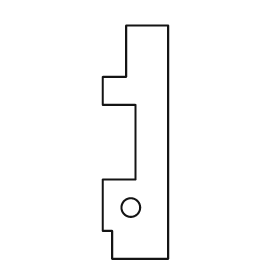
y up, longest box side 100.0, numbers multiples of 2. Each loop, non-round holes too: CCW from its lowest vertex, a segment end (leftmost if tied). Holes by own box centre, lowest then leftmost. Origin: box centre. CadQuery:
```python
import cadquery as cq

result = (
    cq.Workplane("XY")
    .moveTo(-10.0, -50.0)
    .lineTo(14.0, -50.0)
    .lineTo(14.0, 50.0)
    .lineTo(-4.0, 50.0)
    .lineTo(-4.0, 28.0)
    .lineTo(-14.0, 28.0)
    .lineTo(-14.0, 16.0)
    .lineTo(0.0, 16.0)
    .lineTo(0.0, -16.0)
    .lineTo(-14.0, -16.0)
    .lineTo(-14.0, -38.0)
    .lineTo(-10.0, -38.0)
    .close()
    .moveTo(-2.0, -28.0)
    .circle(4.0)
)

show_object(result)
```